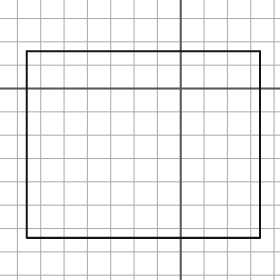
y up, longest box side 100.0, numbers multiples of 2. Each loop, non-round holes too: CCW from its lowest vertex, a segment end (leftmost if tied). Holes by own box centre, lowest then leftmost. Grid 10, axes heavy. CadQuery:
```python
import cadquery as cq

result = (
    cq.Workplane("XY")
    .moveTo(-66.0, -64.0)
    .lineTo(34.0, -64.0)
    .lineTo(34.0, 16.0)
    .lineTo(-66.0, 16.0)
    .close()
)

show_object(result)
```